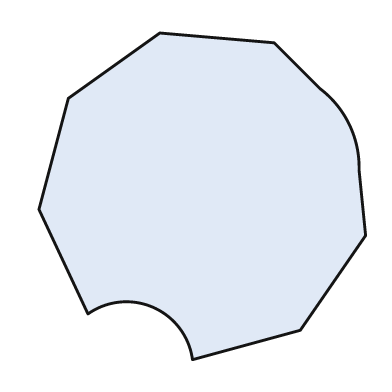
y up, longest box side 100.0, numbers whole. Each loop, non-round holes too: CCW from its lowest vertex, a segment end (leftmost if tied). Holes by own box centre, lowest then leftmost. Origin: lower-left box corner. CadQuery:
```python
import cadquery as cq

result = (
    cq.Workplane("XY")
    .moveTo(47.0, 0.0)
    .lineTo(80.0, 9.0)
    .lineTo(100.0, 38.0)
    .lineTo(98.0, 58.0)
    .threePointArc((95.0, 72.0), (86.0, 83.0))
    .lineTo(72.0, 97.0)
    .lineTo(37.0, 100.0)
    .lineTo(9.0, 80.0)
    .lineTo(0.0, 46.0)
    .lineTo(15.0, 14.0)
    .threePointArc((35.0, 16.0), (47.0, 0.0))
    .close()
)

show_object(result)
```